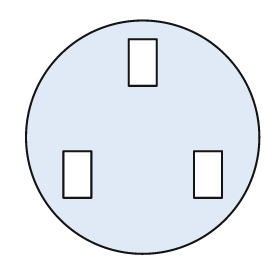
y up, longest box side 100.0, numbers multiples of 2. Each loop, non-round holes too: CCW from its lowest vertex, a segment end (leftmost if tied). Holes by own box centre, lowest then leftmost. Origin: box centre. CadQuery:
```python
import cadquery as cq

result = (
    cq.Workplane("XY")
    .moveTo(0.0, 0.0)
    .circle(50.0)
    .moveTo(-34.0, -26.0)
    .lineTo(-22.0, -26.0)
    .lineTo(-22.0, -6.0)
    .lineTo(-34.0, -6.0)
    .close()
    .moveTo(22.0, -26.0)
    .lineTo(34.0, -26.0)
    .lineTo(34.0, -6.0)
    .lineTo(22.0, -6.0)
    .close()
    .moveTo(-6.0, 22.0)
    .lineTo(6.0, 22.0)
    .lineTo(6.0, 42.0)
    .lineTo(-6.0, 42.0)
    .close()
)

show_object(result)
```